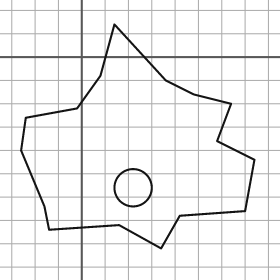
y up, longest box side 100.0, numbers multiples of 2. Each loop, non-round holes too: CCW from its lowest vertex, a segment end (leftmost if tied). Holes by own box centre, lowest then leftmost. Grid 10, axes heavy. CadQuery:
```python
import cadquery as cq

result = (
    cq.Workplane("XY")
    .moveTo(34.0, -82.0)
    .lineTo(42.0, -68.0)
    .lineTo(70.0, -66.0)
    .lineTo(74.0, -44.0)
    .lineTo(58.0, -36.0)
    .lineTo(64.0, -20.0)
    .lineTo(48.0, -16.0)
    .lineTo(36.0, -10.0)
    .lineTo(14.0, 14.0)
    .lineTo(8.0, -8.0)
    .lineTo(-2.0, -22.0)
    .lineTo(-24.0, -26.0)
    .lineTo(-26.0, -40.0)
    .lineTo(-16.0, -64.0)
    .lineTo(-14.0, -74.0)
    .lineTo(16.0, -72.0)
    .close()
    .moveTo(22.0, -56.0)
    .circle(8.0)
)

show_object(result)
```